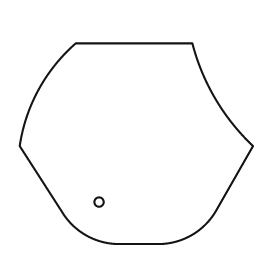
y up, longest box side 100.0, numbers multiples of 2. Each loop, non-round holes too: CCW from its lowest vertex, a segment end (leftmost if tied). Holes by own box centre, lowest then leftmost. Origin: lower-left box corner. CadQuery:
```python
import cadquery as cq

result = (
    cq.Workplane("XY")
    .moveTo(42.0, 0.0)
    .lineTo(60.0, 0.0)
    .threePointArc((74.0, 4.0), (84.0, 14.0))
    .lineTo(100.0, 42.0)
    .threePointArc((84.0, 62.0), (74.0, 86.0))
    .lineTo(24.0, 86.0)
    .threePointArc((8.0, 66.0), (0.0, 42.0))
    .lineTo(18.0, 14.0)
    .threePointArc((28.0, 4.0), (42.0, 0.0))
    .close()
    .moveTo(34.0, 18.0)
    .circle(2.0)
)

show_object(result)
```